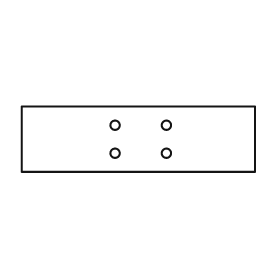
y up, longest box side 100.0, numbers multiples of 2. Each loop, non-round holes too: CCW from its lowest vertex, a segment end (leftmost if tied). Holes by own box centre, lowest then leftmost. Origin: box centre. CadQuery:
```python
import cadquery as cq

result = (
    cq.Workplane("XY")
    .moveTo(-50.0, -14.0)
    .lineTo(50.0, -14.0)
    .lineTo(50.0, 14.0)
    .lineTo(-50.0, 14.0)
    .close()
    .moveTo(-10.0, -6.0)
    .circle(2.0)
    .moveTo(12.0, -6.0)
    .circle(2.0)
    .moveTo(-10.0, 6.0)
    .circle(2.0)
    .moveTo(12.0, 6.0)
    .circle(2.0)
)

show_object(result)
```